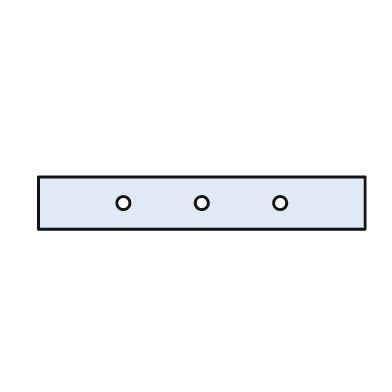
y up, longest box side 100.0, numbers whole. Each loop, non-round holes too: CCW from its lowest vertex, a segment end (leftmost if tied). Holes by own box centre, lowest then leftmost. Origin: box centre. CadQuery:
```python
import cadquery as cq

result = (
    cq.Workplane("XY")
    .moveTo(-50.0, -8.0)
    .lineTo(50.0, -8.0)
    .lineTo(50.0, 8.0)
    .lineTo(-50.0, 8.0)
    .close()
    .moveTo(-24.0, 0.0)
    .circle(2.0)
    .moveTo(0.0, 0.0)
    .circle(2.0)
    .moveTo(24.0, 0.0)
    .circle(2.0)
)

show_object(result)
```